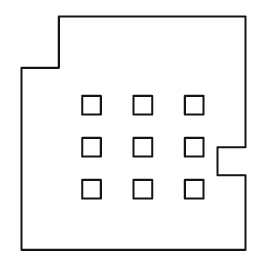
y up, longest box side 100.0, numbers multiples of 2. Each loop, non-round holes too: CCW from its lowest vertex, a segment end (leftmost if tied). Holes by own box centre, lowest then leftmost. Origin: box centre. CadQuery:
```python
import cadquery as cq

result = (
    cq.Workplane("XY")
    .moveTo(-48.0, -50.0)
    .lineTo(48.0, -50.0)
    .lineTo(48.0, -18.0)
    .lineTo(36.0, -18.0)
    .lineTo(36.0, -6.0)
    .lineTo(48.0, -6.0)
    .lineTo(48.0, 50.0)
    .lineTo(-32.0, 50.0)
    .lineTo(-32.0, 28.0)
    .lineTo(-48.0, 28.0)
    .close()
    .moveTo(-22.0, -28.0)
    .lineTo(-14.0, -28.0)
    .lineTo(-14.0, -20.0)
    .lineTo(-22.0, -20.0)
    .close()
    .moveTo(0.0, -28.0)
    .lineTo(8.0, -28.0)
    .lineTo(8.0, -20.0)
    .lineTo(0.0, -20.0)
    .close()
    .moveTo(22.0, -28.0)
    .lineTo(30.0, -28.0)
    .lineTo(30.0, -20.0)
    .lineTo(22.0, -20.0)
    .close()
    .moveTo(-22.0, -10.0)
    .lineTo(-14.0, -10.0)
    .lineTo(-14.0, -2.0)
    .lineTo(-22.0, -2.0)
    .close()
    .moveTo(0.0, -10.0)
    .lineTo(8.0, -10.0)
    .lineTo(8.0, -2.0)
    .lineTo(0.0, -2.0)
    .close()
    .moveTo(22.0, -10.0)
    .lineTo(30.0, -10.0)
    .lineTo(30.0, -2.0)
    .lineTo(22.0, -2.0)
    .close()
    .moveTo(-22.0, 8.0)
    .lineTo(-14.0, 8.0)
    .lineTo(-14.0, 16.0)
    .lineTo(-22.0, 16.0)
    .close()
    .moveTo(0.0, 8.0)
    .lineTo(8.0, 8.0)
    .lineTo(8.0, 16.0)
    .lineTo(0.0, 16.0)
    .close()
    .moveTo(22.0, 8.0)
    .lineTo(30.0, 8.0)
    .lineTo(30.0, 16.0)
    .lineTo(22.0, 16.0)
    .close()
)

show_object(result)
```